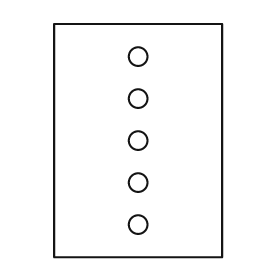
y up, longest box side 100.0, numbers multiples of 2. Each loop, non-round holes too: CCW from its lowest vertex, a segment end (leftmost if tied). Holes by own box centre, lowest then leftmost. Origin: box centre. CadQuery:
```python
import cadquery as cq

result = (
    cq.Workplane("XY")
    .moveTo(-36.0, -50.0)
    .lineTo(36.0, -50.0)
    .lineTo(36.0, 50.0)
    .lineTo(-36.0, 50.0)
    .close()
    .moveTo(0.0, -36.0)
    .circle(4.0)
    .moveTo(0.0, -18.0)
    .circle(4.0)
    .moveTo(0.0, 0.0)
    .circle(4.0)
    .moveTo(0.0, 18.0)
    .circle(4.0)
    .moveTo(0.0, 36.0)
    .circle(4.0)
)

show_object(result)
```